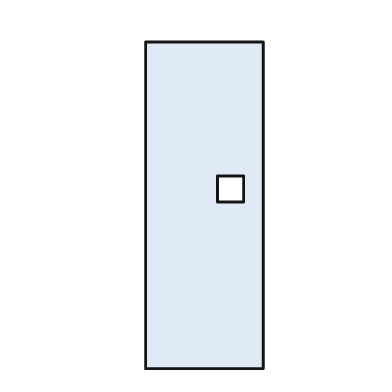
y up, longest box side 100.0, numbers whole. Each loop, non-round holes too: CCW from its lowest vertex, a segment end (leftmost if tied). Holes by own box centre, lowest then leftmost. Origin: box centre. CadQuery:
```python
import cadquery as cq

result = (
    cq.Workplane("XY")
    .moveTo(-18.0, -50.0)
    .lineTo(18.0, -50.0)
    .lineTo(18.0, 50.0)
    .lineTo(-18.0, 50.0)
    .close()
    .moveTo(4.0, 1.0)
    .lineTo(12.0, 1.0)
    .lineTo(12.0, 9.0)
    .lineTo(4.0, 9.0)
    .close()
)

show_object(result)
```